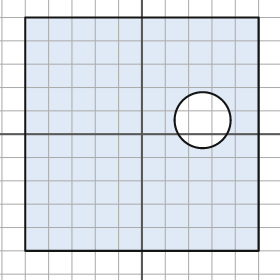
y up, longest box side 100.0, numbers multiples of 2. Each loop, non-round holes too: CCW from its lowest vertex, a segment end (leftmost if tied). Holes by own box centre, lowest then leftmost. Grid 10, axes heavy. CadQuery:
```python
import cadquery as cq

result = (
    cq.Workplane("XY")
    .moveTo(-50.0, -50.0)
    .lineTo(50.0, -50.0)
    .lineTo(50.0, 50.0)
    .lineTo(-50.0, 50.0)
    .close()
    .moveTo(26.0, 6.0)
    .circle(12.0)
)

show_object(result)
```